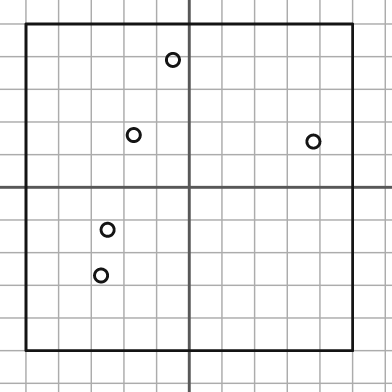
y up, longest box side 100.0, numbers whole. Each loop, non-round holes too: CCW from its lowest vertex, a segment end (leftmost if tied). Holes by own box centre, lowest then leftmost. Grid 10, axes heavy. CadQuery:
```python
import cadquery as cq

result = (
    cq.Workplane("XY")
    .moveTo(-50.0, -50.0)
    .lineTo(50.0, -50.0)
    .lineTo(50.0, 50.0)
    .lineTo(-50.0, 50.0)
    .close()
    .moveTo(-27.0, -27.0)
    .circle(2.0)
    .moveTo(-25.0, -13.0)
    .circle(2.0)
    .moveTo(38.0, 14.0)
    .circle(2.0)
    .moveTo(-17.0, 16.0)
    .circle(2.0)
    .moveTo(-5.0, 39.0)
    .circle(2.0)
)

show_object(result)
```